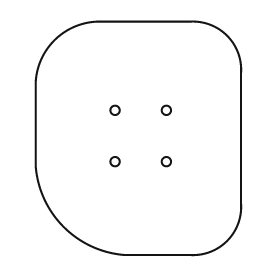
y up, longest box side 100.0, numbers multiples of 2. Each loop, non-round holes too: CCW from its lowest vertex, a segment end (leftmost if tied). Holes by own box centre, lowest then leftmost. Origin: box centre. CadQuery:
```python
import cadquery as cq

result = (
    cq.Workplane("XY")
    .moveTo(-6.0, -50.0)
    .lineTo(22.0, -50.0)
    .threePointArc((38.0, -44.0), (44.0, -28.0))
    .lineTo(44.0, 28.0)
    .threePointArc((38.0, 44.0), (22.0, 50.0))
    .lineTo(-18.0, 50.0)
    .threePointArc((-36.0, 42.0), (-44.0, 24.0))
    .lineTo(-44.0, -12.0)
    .threePointArc((-32.0, -38.0), (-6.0, -50.0))
    .close()
    .moveTo(-10.0, -10.0)
    .circle(2.0)
    .moveTo(12.0, -10.0)
    .circle(2.0)
    .moveTo(-10.0, 12.0)
    .circle(2.0)
    .moveTo(12.0, 12.0)
    .circle(2.0)
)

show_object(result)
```